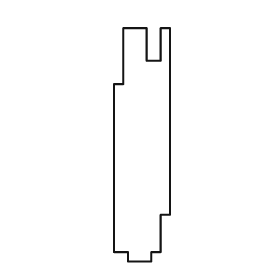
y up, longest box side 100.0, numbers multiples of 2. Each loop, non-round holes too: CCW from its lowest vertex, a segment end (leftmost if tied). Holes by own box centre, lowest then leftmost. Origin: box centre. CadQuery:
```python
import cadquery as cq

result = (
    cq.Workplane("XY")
    .moveTo(-6.0, -50.0)
    .lineTo(4.0, -50.0)
    .lineTo(4.0, -46.0)
    .lineTo(8.0, -46.0)
    .lineTo(8.0, -30.0)
    .lineTo(12.0, -30.0)
    .lineTo(12.0, 50.0)
    .lineTo(8.0, 50.0)
    .lineTo(8.0, 36.0)
    .lineTo(2.0, 36.0)
    .lineTo(2.0, 50.0)
    .lineTo(-8.0, 50.0)
    .lineTo(-8.0, 26.0)
    .lineTo(-12.0, 26.0)
    .lineTo(-12.0, -46.0)
    .lineTo(-6.0, -46.0)
    .close()
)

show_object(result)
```